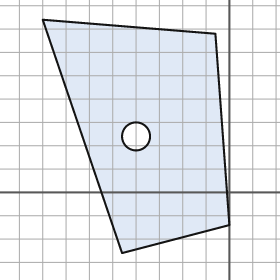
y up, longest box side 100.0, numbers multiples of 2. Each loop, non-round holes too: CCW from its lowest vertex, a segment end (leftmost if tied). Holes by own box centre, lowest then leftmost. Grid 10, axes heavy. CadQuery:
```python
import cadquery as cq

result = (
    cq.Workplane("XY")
    .moveTo(-46.0, -26.0)
    .lineTo(0.0, -14.0)
    .lineTo(-6.0, 68.0)
    .lineTo(-80.0, 74.0)
    .close()
    .moveTo(-40.0, 24.0)
    .circle(6.0)
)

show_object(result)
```